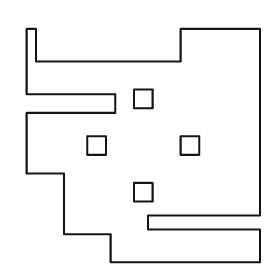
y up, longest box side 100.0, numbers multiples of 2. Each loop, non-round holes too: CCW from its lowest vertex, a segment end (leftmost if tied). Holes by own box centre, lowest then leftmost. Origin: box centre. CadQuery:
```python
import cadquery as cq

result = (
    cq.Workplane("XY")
    .moveTo(-14.0, -50.0)
    .lineTo(50.0, -50.0)
    .lineTo(50.0, -36.0)
    .lineTo(2.0, -36.0)
    .lineTo(2.0, -30.0)
    .lineTo(50.0, -30.0)
    .lineTo(50.0, 50.0)
    .lineTo(16.0, 50.0)
    .lineTo(16.0, 36.0)
    .lineTo(-46.0, 36.0)
    .lineTo(-46.0, 50.0)
    .lineTo(-50.0, 50.0)
    .lineTo(-50.0, 22.0)
    .lineTo(-12.0, 22.0)
    .lineTo(-12.0, 14.0)
    .lineTo(-50.0, 14.0)
    .lineTo(-50.0, -12.0)
    .lineTo(-34.0, -12.0)
    .lineTo(-34.0, -38.0)
    .lineTo(-14.0, -38.0)
    .close()
    .moveTo(-4.0, -24.0)
    .lineTo(4.0, -24.0)
    .lineTo(4.0, -16.0)
    .lineTo(-4.0, -16.0)
    .close()
    .moveTo(-24.0, -4.0)
    .lineTo(-16.0, -4.0)
    .lineTo(-16.0, 4.0)
    .lineTo(-24.0, 4.0)
    .close()
    .moveTo(16.0, -4.0)
    .lineTo(24.0, -4.0)
    .lineTo(24.0, 4.0)
    .lineTo(16.0, 4.0)
    .close()
    .moveTo(-4.0, 16.0)
    .lineTo(4.0, 16.0)
    .lineTo(4.0, 24.0)
    .lineTo(-4.0, 24.0)
    .close()
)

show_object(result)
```